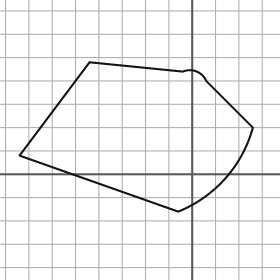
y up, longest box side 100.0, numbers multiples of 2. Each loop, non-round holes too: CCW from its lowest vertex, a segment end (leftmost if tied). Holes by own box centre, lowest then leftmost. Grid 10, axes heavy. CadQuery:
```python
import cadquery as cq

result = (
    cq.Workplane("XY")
    .moveTo(-6.0, -16.0)
    .threePointArc((14.0, -2.0), (26.0, 20.0))
    .lineTo(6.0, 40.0)
    .threePointArc((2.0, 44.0), (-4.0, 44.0))
    .lineTo(-44.0, 48.0)
    .lineTo(-74.0, 8.0)
    .close()
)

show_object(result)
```